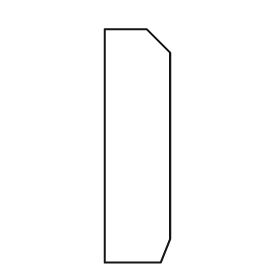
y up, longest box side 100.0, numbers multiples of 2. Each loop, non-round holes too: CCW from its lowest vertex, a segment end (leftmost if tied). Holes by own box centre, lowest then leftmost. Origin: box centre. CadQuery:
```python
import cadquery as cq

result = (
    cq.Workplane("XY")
    .moveTo(-14.0, -50.0)
    .lineTo(10.0, -50.0)
    .lineTo(14.0, -40.0)
    .lineTo(14.0, 40.0)
    .lineTo(4.0, 50.0)
    .lineTo(-14.0, 50.0)
    .close()
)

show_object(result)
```